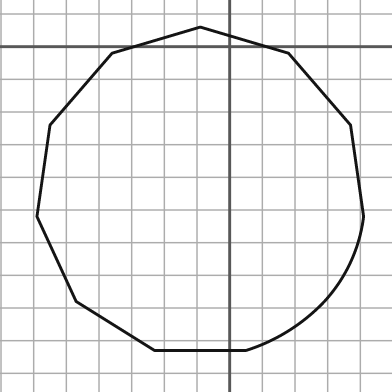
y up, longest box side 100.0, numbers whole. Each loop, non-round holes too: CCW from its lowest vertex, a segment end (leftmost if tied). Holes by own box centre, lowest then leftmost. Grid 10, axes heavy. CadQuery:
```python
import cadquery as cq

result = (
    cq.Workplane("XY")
    .moveTo(-23.0, -93.0)
    .lineTo(5.0, -93.0)
    .threePointArc((18.0, -87.0), (29.0, -78.0))
    .threePointArc((37.0, -66.0), (41.0, -52.0))
    .lineTo(37.0, -24.0)
    .lineTo(18.0, -2.0)
    .lineTo(-9.0, 6.0)
    .lineTo(-36.0, -2.0)
    .lineTo(-55.0, -24.0)
    .lineTo(-59.0, -52.0)
    .lineTo(-47.0, -78.0)
    .close()
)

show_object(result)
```